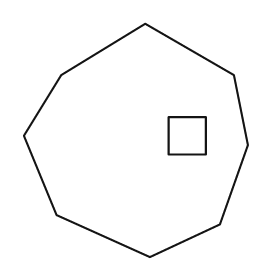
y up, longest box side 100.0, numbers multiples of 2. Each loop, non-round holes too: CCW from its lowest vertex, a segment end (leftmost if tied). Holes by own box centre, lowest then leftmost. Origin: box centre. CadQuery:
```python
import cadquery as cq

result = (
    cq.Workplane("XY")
    .moveTo(6.0, -50.0)
    .lineTo(36.0, -36.0)
    .lineTo(48.0, -2.0)
    .lineTo(42.0, 28.0)
    .lineTo(4.0, 50.0)
    .lineTo(-32.0, 28.0)
    .lineTo(-48.0, 2.0)
    .lineTo(-34.0, -32.0)
    .close()
    .moveTo(14.0, -6.0)
    .lineTo(30.0, -6.0)
    .lineTo(30.0, 10.0)
    .lineTo(14.0, 10.0)
    .close()
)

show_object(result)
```